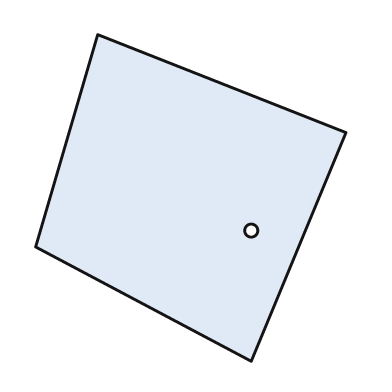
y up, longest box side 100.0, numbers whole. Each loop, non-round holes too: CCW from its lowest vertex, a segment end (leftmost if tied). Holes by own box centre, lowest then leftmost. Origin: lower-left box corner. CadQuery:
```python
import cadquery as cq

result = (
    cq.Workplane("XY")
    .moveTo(66.0, 0.0)
    .lineTo(95.0, 70.0)
    .lineTo(19.0, 100.0)
    .lineTo(0.0, 35.0)
    .close()
    .moveTo(66.0, 40.0)
    .circle(2.0)
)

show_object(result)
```